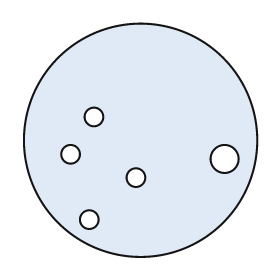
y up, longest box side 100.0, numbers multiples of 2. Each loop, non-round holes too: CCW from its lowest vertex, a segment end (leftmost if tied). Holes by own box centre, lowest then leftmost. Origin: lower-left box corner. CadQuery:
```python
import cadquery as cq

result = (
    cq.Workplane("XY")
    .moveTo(50.0, 50.0)
    .circle(50.0)
    .moveTo(28.0, 16.0)
    .circle(4.0)
    .moveTo(48.0, 34.0)
    .circle(4.0)
    .moveTo(86.0, 42.0)
    .circle(6.0)
    .moveTo(20.0, 44.0)
    .circle(4.0)
    .moveTo(30.0, 60.0)
    .circle(4.0)
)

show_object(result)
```